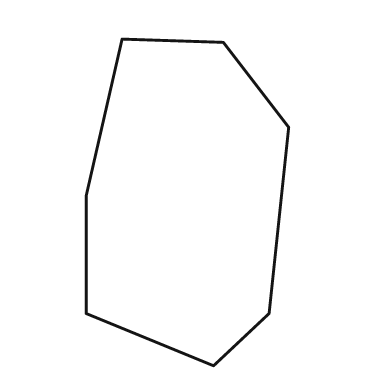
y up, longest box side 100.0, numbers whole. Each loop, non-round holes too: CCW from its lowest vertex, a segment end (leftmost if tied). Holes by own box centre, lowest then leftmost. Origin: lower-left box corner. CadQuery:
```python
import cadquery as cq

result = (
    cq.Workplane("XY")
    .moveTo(39.0, 0.0)
    .lineTo(56.0, 16.0)
    .lineTo(62.0, 73.0)
    .lineTo(42.0, 99.0)
    .lineTo(11.0, 100.0)
    .lineTo(0.0, 52.0)
    .lineTo(0.0, 16.0)
    .close()
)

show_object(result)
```